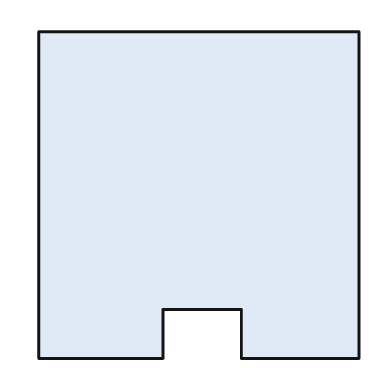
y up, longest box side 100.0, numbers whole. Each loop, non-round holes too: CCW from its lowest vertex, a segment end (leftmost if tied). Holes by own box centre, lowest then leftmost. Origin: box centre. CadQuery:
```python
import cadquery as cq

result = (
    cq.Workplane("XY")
    .moveTo(-49.0, -50.0)
    .lineTo(-11.0, -50.0)
    .lineTo(-11.0, -35.0)
    .lineTo(13.0, -35.0)
    .lineTo(13.0, -50.0)
    .lineTo(49.0, -50.0)
    .lineTo(49.0, 50.0)
    .lineTo(-49.0, 50.0)
    .close()
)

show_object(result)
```